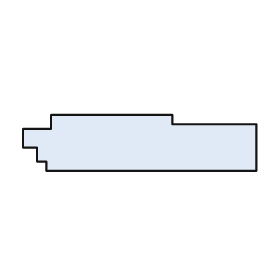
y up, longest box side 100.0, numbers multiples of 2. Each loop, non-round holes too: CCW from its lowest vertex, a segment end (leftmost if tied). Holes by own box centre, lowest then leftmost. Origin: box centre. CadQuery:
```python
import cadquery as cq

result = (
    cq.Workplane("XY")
    .moveTo(-40.0, -12.0)
    .lineTo(50.0, -12.0)
    .lineTo(50.0, 8.0)
    .lineTo(14.0, 8.0)
    .lineTo(14.0, 12.0)
    .lineTo(-38.0, 12.0)
    .lineTo(-38.0, 6.0)
    .lineTo(-50.0, 6.0)
    .lineTo(-50.0, -2.0)
    .lineTo(-44.0, -2.0)
    .lineTo(-44.0, -8.0)
    .lineTo(-40.0, -8.0)
    .close()
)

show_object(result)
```